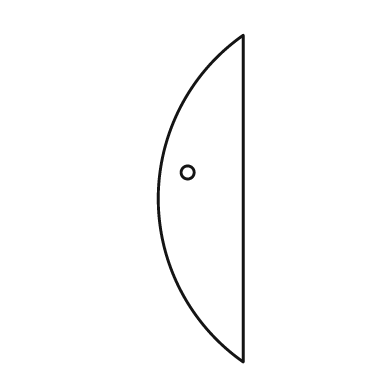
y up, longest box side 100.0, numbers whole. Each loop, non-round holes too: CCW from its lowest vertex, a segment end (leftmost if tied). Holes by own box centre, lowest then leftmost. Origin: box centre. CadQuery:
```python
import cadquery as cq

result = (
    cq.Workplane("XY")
    .moveTo(13.0, -50.0)
    .lineTo(13.0, 50.0)
    .threePointArc((-13.0, 0.0), (13.0, -50.0))
    .close()
    .moveTo(-4.0, 8.0)
    .circle(2.0)
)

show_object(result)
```